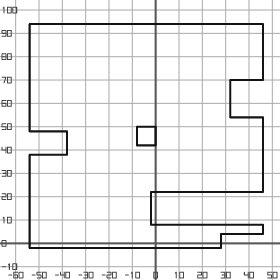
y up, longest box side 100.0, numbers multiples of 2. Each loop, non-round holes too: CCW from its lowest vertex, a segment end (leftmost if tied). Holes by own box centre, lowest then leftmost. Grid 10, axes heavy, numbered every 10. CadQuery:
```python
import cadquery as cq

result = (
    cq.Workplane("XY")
    .moveTo(-54.0, -2.0)
    .lineTo(28.0, -2.0)
    .lineTo(28.0, 4.0)
    .lineTo(46.0, 4.0)
    .lineTo(46.0, 8.0)
    .lineTo(-2.0, 8.0)
    .lineTo(-2.0, 22.0)
    .lineTo(46.0, 22.0)
    .lineTo(46.0, 54.0)
    .lineTo(32.0, 54.0)
    .lineTo(32.0, 70.0)
    .lineTo(46.0, 70.0)
    .lineTo(46.0, 94.0)
    .lineTo(-54.0, 94.0)
    .lineTo(-54.0, 48.0)
    .lineTo(-38.0, 48.0)
    .lineTo(-38.0, 38.0)
    .lineTo(-54.0, 38.0)
    .close()
    .moveTo(-8.0, 42.0)
    .lineTo(0.0, 42.0)
    .lineTo(0.0, 50.0)
    .lineTo(-8.0, 50.0)
    .close()
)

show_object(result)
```